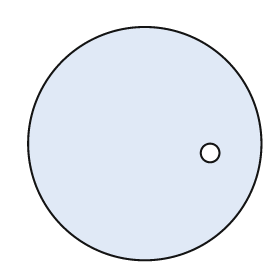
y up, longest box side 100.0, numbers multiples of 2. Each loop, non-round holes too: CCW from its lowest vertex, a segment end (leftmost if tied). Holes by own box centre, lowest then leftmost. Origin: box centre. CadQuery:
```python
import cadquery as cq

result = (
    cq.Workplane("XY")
    .moveTo(0.0, 0.0)
    .circle(50.0)
    .moveTo(28.0, -4.0)
    .circle(4.0)
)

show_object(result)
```